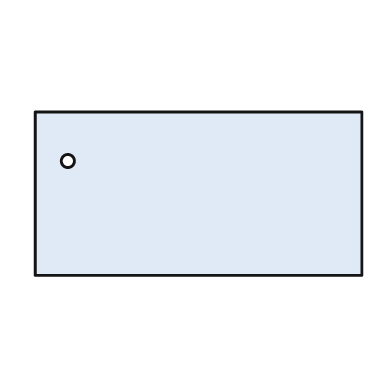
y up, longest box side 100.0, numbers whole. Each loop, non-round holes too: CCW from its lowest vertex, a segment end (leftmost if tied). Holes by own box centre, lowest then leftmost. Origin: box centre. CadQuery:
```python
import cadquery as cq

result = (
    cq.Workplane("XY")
    .moveTo(-50.0, -25.0)
    .lineTo(50.0, -25.0)
    .lineTo(50.0, 25.0)
    .lineTo(-50.0, 25.0)
    .close()
    .moveTo(-40.0, 10.0)
    .circle(2.0)
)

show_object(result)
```